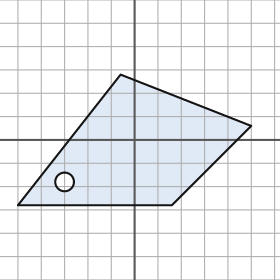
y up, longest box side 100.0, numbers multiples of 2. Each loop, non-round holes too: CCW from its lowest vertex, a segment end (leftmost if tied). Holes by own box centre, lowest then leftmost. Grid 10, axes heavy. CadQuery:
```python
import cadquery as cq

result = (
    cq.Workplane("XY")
    .moveTo(-50.0, -28.0)
    .lineTo(16.0, -28.0)
    .lineTo(50.0, 6.0)
    .lineTo(-6.0, 28.0)
    .close()
    .moveTo(-30.0, -18.0)
    .circle(4.0)
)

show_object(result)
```